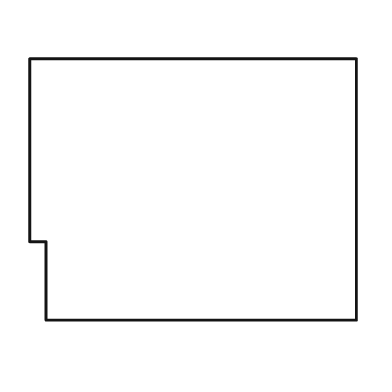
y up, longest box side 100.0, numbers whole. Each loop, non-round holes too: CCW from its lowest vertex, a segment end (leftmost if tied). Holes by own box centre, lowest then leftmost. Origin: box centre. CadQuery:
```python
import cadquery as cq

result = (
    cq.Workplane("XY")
    .moveTo(-45.0, -40.0)
    .lineTo(50.0, -40.0)
    .lineTo(50.0, 40.0)
    .lineTo(-50.0, 40.0)
    .lineTo(-50.0, -16.0)
    .lineTo(-45.0, -16.0)
    .close()
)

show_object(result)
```